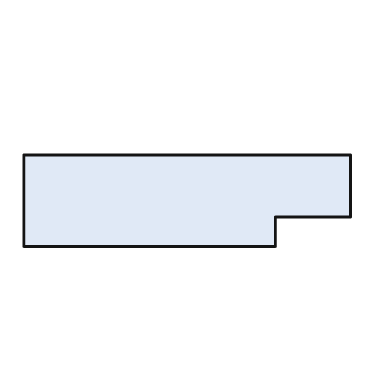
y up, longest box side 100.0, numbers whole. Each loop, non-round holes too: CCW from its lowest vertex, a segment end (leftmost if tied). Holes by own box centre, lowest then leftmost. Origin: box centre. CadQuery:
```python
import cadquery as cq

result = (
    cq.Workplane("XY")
    .moveTo(-50.0, -14.0)
    .lineTo(27.0, -14.0)
    .lineTo(27.0, -5.0)
    .lineTo(50.0, -5.0)
    .lineTo(50.0, 14.0)
    .lineTo(-50.0, 14.0)
    .close()
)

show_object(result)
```